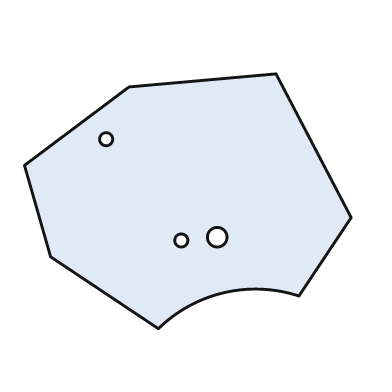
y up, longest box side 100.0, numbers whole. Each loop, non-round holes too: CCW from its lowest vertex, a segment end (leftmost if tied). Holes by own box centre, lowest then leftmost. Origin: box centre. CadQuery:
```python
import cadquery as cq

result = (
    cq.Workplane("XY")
    .moveTo(-9.0, -39.0)
    .threePointArc((11.0, -28.0), (34.0, -29.0))
    .lineTo(50.0, -5.0)
    .lineTo(27.0, 39.0)
    .lineTo(-18.0, 35.0)
    .lineTo(-50.0, 11.0)
    .lineTo(-42.0, -17.0)
    .close()
    .moveTo(-2.0, -12.0)
    .circle(2.0)
    .moveTo(9.0, -11.0)
    .circle(3.0)
    .moveTo(-25.0, 19.0)
    .circle(2.0)
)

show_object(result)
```